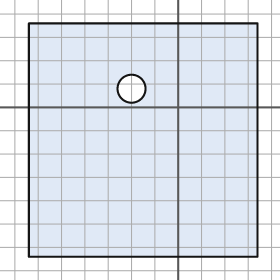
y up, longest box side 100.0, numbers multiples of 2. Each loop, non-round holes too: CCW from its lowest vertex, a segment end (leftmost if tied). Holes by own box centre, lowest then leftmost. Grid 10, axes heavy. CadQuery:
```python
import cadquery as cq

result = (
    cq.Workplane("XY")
    .moveTo(-64.0, -64.0)
    .lineTo(34.0, -64.0)
    .lineTo(34.0, 36.0)
    .lineTo(-64.0, 36.0)
    .close()
    .moveTo(-20.0, 8.0)
    .circle(6.0)
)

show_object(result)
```